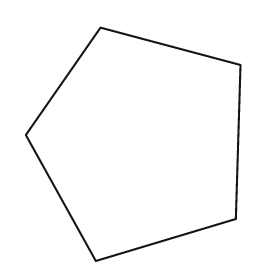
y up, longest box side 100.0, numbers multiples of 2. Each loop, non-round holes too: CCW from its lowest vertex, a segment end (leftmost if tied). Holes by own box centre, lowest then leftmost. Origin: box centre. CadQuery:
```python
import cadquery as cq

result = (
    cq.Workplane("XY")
    .moveTo(-16.0, -50.0)
    .lineTo(44.0, -32.0)
    .lineTo(46.0, 34.0)
    .lineTo(-14.0, 50.0)
    .lineTo(-46.0, 4.0)
    .close()
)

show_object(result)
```